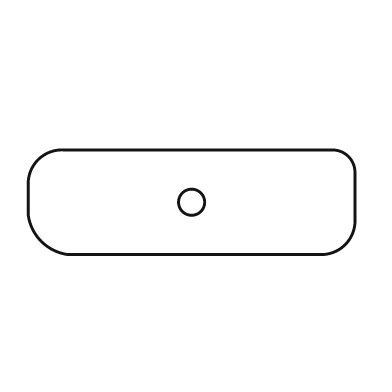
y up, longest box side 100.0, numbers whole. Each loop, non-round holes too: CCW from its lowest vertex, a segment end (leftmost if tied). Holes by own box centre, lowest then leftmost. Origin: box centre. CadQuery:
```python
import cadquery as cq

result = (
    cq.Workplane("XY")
    .moveTo(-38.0, -16.0)
    .lineTo(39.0, -16.0)
    .threePointArc((47.0, -13.0), (50.0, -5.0))
    .lineTo(50.0, 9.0)
    .threePointArc((48.0, 14.0), (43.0, 16.0))
    .lineTo(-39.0, 16.0)
    .threePointArc((-47.0, 13.0), (-50.0, 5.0))
    .lineTo(-50.0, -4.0)
    .threePointArc((-46.0, -12.0), (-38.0, -16.0))
    .close()
    .moveTo(0.0, 0.0)
    .circle(4.0)
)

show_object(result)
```